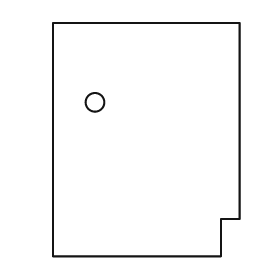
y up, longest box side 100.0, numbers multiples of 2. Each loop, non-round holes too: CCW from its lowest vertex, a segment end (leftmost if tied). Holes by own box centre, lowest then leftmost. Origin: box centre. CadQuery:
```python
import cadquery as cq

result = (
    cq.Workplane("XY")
    .moveTo(-40.0, -50.0)
    .lineTo(32.0, -50.0)
    .lineTo(32.0, -34.0)
    .lineTo(40.0, -34.0)
    .lineTo(40.0, 50.0)
    .lineTo(-40.0, 50.0)
    .close()
    .moveTo(-22.0, 16.0)
    .circle(4.0)
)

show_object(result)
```